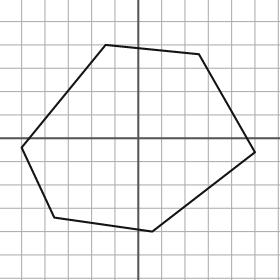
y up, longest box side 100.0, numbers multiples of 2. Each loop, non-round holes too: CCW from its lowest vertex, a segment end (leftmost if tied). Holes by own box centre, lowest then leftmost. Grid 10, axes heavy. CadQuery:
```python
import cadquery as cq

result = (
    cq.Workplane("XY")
    .moveTo(6.0, -40.0)
    .lineTo(50.0, -6.0)
    .lineTo(26.0, 36.0)
    .lineTo(-14.0, 40.0)
    .lineTo(-50.0, -4.0)
    .lineTo(-36.0, -34.0)
    .close()
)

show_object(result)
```